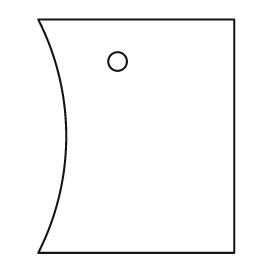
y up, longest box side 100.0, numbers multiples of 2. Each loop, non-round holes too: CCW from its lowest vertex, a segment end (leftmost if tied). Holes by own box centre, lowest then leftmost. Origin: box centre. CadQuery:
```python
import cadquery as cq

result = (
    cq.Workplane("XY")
    .moveTo(-42.0, -50.0)
    .lineTo(42.0, -50.0)
    .lineTo(42.0, 50.0)
    .lineTo(-42.0, 50.0)
    .threePointArc((-30.0, 0.0), (-42.0, -50.0))
    .close()
    .moveTo(-8.0, 32.0)
    .circle(4.0)
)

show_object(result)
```